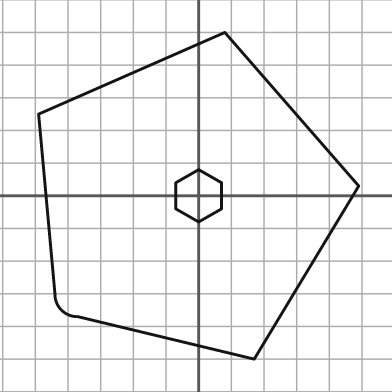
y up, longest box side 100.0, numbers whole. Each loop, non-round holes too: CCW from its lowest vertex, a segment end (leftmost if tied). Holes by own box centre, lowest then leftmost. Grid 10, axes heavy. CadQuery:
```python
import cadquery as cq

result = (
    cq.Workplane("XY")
    .moveTo(17.0, -50.0)
    .lineTo(49.0, 3.0)
    .lineTo(8.0, 50.0)
    .lineTo(-49.0, 25.0)
    .lineTo(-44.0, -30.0)
    .threePointArc((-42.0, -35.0), (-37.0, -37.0))
    .close()
    .moveTo(0.0, -8.0)
    .lineTo(7.0, -4.0)
    .lineTo(7.0, 4.0)
    .lineTo(0.0, 8.0)
    .lineTo(-7.0, 4.0)
    .lineTo(-7.0, -4.0)
    .close()
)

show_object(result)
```